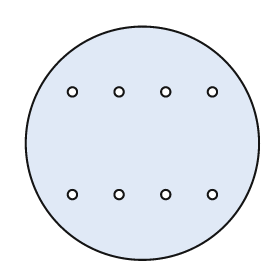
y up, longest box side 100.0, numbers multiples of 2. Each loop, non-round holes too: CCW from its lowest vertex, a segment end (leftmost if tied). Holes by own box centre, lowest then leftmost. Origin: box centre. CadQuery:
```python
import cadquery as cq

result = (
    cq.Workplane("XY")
    .moveTo(0.0, 0.0)
    .circle(50.0)
    .moveTo(-30.0, -22.0)
    .circle(2.0)
    .moveTo(-10.0, -22.0)
    .circle(2.0)
    .moveTo(10.0, -22.0)
    .circle(2.0)
    .moveTo(30.0, -22.0)
    .circle(2.0)
    .moveTo(-30.0, 22.0)
    .circle(2.0)
    .moveTo(-10.0, 22.0)
    .circle(2.0)
    .moveTo(10.0, 22.0)
    .circle(2.0)
    .moveTo(30.0, 22.0)
    .circle(2.0)
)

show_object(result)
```